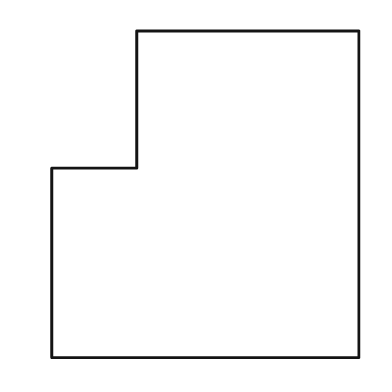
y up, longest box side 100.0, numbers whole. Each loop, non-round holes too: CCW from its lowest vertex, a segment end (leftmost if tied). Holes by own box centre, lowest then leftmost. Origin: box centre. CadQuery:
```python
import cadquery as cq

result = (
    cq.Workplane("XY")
    .moveTo(-47.0, -50.0)
    .lineTo(47.0, -50.0)
    .lineTo(47.0, 50.0)
    .lineTo(-21.0, 50.0)
    .lineTo(-21.0, 8.0)
    .lineTo(-47.0, 8.0)
    .close()
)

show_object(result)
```